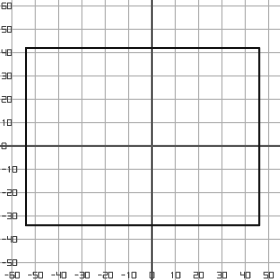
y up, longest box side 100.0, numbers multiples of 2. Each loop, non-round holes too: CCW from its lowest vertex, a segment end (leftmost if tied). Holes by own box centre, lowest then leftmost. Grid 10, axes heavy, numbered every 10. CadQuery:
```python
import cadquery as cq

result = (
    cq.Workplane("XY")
    .moveTo(-54.0, -34.0)
    .lineTo(46.0, -34.0)
    .lineTo(46.0, 42.0)
    .lineTo(-54.0, 42.0)
    .close()
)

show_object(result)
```